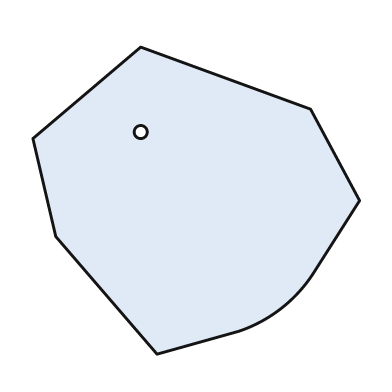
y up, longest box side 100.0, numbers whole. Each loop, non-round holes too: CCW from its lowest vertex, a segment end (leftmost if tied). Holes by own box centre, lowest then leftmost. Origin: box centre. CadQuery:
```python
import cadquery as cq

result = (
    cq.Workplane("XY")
    .moveTo(-12.0, -47.0)
    .lineTo(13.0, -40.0)
    .threePointArc((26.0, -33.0), (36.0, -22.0))
    .lineTo(50.0, 0.0)
    .lineTo(35.0, 28.0)
    .lineTo(-17.0, 47.0)
    .lineTo(-50.0, 19.0)
    .lineTo(-43.0, -11.0)
    .close()
    .moveTo(-17.0, 21.0)
    .circle(2.0)
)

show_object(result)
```